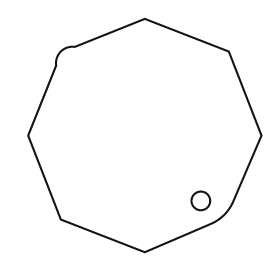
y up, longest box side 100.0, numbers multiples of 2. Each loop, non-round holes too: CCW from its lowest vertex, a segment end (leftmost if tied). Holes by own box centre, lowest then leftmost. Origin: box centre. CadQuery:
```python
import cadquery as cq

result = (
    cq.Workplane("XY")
    .moveTo(0.0, -50.0)
    .lineTo(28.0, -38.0)
    .threePointArc((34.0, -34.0), (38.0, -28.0))
    .lineTo(50.0, 0.0)
    .lineTo(36.0, 36.0)
    .lineTo(0.0, 50.0)
    .lineTo(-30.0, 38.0)
    .threePointArc((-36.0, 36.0), (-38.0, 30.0))
    .lineTo(-50.0, 0.0)
    .lineTo(-36.0, -36.0)
    .close()
    .moveTo(24.0, -28.0)
    .circle(4.0)
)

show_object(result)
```